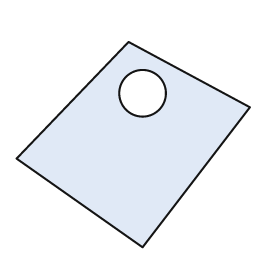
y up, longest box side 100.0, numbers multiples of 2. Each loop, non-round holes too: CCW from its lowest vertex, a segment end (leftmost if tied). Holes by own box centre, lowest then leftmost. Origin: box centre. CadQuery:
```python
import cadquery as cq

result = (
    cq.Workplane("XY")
    .moveTo(4.0, -44.0)
    .lineTo(50.0, 16.0)
    .lineTo(-2.0, 44.0)
    .lineTo(-50.0, -6.0)
    .close()
    .moveTo(4.0, 22.0)
    .circle(10.0)
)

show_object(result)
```